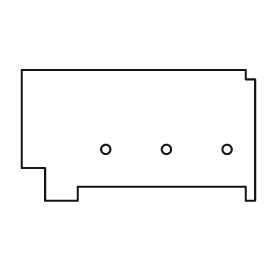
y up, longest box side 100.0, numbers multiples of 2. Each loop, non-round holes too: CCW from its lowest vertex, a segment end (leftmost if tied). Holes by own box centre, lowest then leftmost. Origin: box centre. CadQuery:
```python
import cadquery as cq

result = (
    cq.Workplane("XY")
    .moveTo(-40.0, -28.0)
    .lineTo(-26.0, -28.0)
    .lineTo(-26.0, -22.0)
    .lineTo(46.0, -22.0)
    .lineTo(46.0, -28.0)
    .lineTo(50.0, -28.0)
    .lineTo(50.0, 24.0)
    .lineTo(46.0, 24.0)
    .lineTo(46.0, 28.0)
    .lineTo(-50.0, 28.0)
    .lineTo(-50.0, -14.0)
    .lineTo(-40.0, -14.0)
    .close()
    .moveTo(-14.0, -6.0)
    .circle(2.0)
    .moveTo(12.0, -6.0)
    .circle(2.0)
    .moveTo(38.0, -6.0)
    .circle(2.0)
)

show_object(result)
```